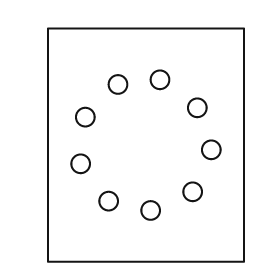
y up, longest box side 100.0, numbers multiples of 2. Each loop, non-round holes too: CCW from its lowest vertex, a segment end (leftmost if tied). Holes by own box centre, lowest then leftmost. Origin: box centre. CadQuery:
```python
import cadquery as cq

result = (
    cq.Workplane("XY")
    .moveTo(-42.0, -50.0)
    .lineTo(42.0, -50.0)
    .lineTo(42.0, 50.0)
    .lineTo(-42.0, 50.0)
    .close()
    .moveTo(2.0, -28.0)
    .circle(4.0)
    .moveTo(-16.0, -24.0)
    .circle(4.0)
    .moveTo(20.0, -20.0)
    .circle(4.0)
    .moveTo(-28.0, -8.0)
    .circle(4.0)
    .moveTo(28.0, -2.0)
    .circle(4.0)
    .moveTo(-26.0, 12.0)
    .circle(4.0)
    .moveTo(22.0, 16.0)
    .circle(4.0)
    .moveTo(-12.0, 26.0)
    .circle(4.0)
    .moveTo(6.0, 28.0)
    .circle(4.0)
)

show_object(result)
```